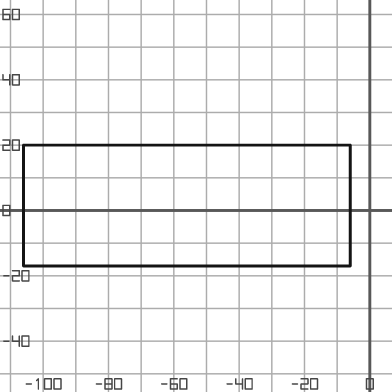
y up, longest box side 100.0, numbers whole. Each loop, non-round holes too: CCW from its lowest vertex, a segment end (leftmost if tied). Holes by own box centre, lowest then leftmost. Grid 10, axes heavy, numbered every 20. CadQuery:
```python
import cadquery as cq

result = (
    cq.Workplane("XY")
    .moveTo(-106.0, -17.0)
    .lineTo(-6.0, -17.0)
    .lineTo(-6.0, 20.0)
    .lineTo(-106.0, 20.0)
    .close()
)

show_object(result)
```